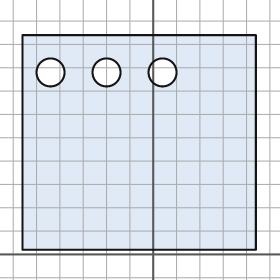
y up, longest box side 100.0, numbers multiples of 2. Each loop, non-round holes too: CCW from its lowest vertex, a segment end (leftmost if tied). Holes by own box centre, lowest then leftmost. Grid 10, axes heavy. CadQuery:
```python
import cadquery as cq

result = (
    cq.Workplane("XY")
    .moveTo(-56.0, 2.0)
    .lineTo(44.0, 2.0)
    .lineTo(44.0, 94.0)
    .lineTo(-56.0, 94.0)
    .close()
    .moveTo(-44.0, 78.0)
    .circle(6.0)
    .moveTo(-20.0, 78.0)
    .circle(6.0)
    .moveTo(4.0, 78.0)
    .circle(6.0)
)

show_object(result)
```